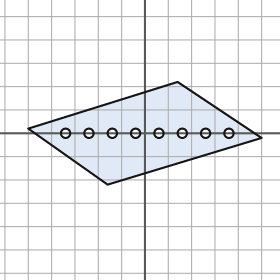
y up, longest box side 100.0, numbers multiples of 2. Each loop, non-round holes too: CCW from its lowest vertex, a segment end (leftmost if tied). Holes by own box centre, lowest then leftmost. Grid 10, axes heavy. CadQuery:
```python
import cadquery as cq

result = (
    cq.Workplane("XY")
    .moveTo(-16.0, -22.0)
    .lineTo(50.0, -2.0)
    .lineTo(14.0, 22.0)
    .lineTo(-50.0, 2.0)
    .close()
    .moveTo(-34.0, 0.0)
    .circle(2.0)
    .moveTo(-24.0, 0.0)
    .circle(2.0)
    .moveTo(-14.0, 0.0)
    .circle(2.0)
    .moveTo(-4.0, 0.0)
    .circle(2.0)
    .moveTo(6.0, 0.0)
    .circle(2.0)
    .moveTo(16.0, 0.0)
    .circle(2.0)
    .moveTo(26.0, 0.0)
    .circle(2.0)
    .moveTo(36.0, 0.0)
    .circle(2.0)
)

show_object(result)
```